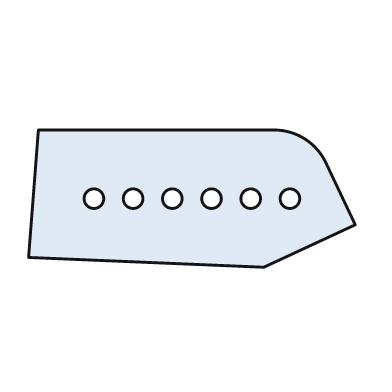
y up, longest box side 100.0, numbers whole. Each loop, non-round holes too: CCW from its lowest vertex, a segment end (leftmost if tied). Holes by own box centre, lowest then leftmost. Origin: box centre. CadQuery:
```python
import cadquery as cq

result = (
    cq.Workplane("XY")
    .moveTo(22.0, -21.0)
    .lineTo(50.0, -8.0)
    .lineTo(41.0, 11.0)
    .threePointArc((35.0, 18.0), (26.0, 21.0))
    .lineTo(-47.0, 21.0)
    .lineTo(-50.0, -18.0)
    .close()
    .moveTo(-30.0, 0.0)
    .circle(3.0)
    .moveTo(-18.0, 0.0)
    .circle(3.0)
    .moveTo(-6.0, 0.0)
    .circle(3.0)
    .moveTo(6.0, 0.0)
    .circle(3.0)
    .moveTo(18.0, 0.0)
    .circle(3.0)
    .moveTo(30.0, 0.0)
    .circle(3.0)
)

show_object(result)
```